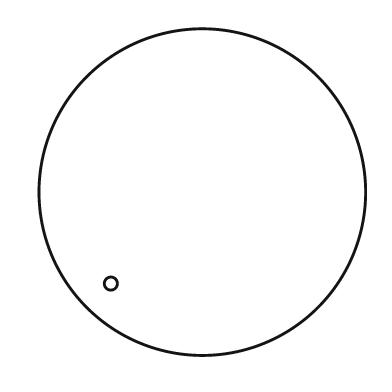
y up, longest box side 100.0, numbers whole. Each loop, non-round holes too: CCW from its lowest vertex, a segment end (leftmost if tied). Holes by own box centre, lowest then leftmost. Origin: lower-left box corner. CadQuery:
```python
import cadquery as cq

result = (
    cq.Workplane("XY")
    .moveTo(50.0, 50.0)
    .circle(50.0)
    .moveTo(22.0, 22.0)
    .circle(2.0)
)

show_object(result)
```